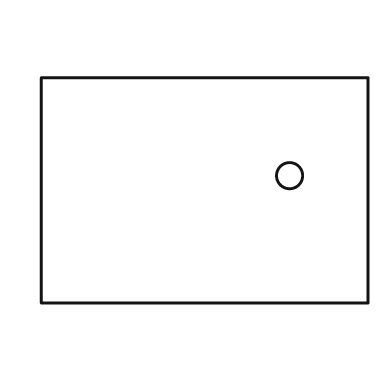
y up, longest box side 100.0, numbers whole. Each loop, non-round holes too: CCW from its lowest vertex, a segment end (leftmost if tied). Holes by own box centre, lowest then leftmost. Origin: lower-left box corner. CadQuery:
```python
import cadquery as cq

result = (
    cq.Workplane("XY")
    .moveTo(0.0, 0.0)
    .lineTo(100.0, 0.0)
    .lineTo(100.0, 69.0)
    .lineTo(0.0, 69.0)
    .close()
    .moveTo(76.0, 39.0)
    .circle(4.0)
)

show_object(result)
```